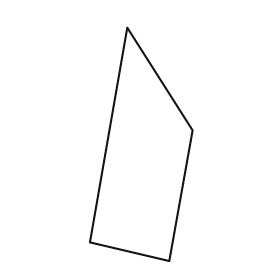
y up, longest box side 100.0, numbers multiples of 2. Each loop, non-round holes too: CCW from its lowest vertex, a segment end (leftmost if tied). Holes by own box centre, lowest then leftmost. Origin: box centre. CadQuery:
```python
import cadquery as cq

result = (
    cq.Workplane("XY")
    .moveTo(12.0, -50.0)
    .lineTo(22.0, 6.0)
    .lineTo(-6.0, 50.0)
    .lineTo(-22.0, -42.0)
    .close()
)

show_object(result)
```